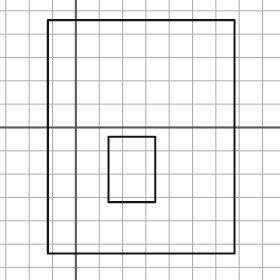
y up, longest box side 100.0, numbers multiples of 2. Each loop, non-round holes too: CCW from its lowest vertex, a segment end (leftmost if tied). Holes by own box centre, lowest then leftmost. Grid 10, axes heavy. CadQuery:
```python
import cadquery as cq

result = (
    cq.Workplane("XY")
    .moveTo(-12.0, -54.0)
    .lineTo(68.0, -54.0)
    .lineTo(68.0, 46.0)
    .lineTo(-12.0, 46.0)
    .close()
    .moveTo(14.0, -32.0)
    .lineTo(34.0, -32.0)
    .lineTo(34.0, -4.0)
    .lineTo(14.0, -4.0)
    .close()
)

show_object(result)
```